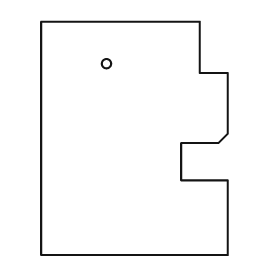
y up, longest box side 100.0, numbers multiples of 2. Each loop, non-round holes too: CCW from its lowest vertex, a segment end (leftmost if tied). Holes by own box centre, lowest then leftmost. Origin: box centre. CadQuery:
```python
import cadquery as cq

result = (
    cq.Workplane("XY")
    .moveTo(-40.0, -50.0)
    .lineTo(40.0, -50.0)
    .lineTo(40.0, -18.0)
    .lineTo(20.0, -18.0)
    .lineTo(20.0, -2.0)
    .lineTo(36.0, -2.0)
    .lineTo(40.0, 2.0)
    .lineTo(40.0, 28.0)
    .lineTo(28.0, 28.0)
    .lineTo(28.0, 50.0)
    .lineTo(-40.0, 50.0)
    .close()
    .moveTo(-12.0, 32.0)
    .circle(2.0)
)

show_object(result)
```